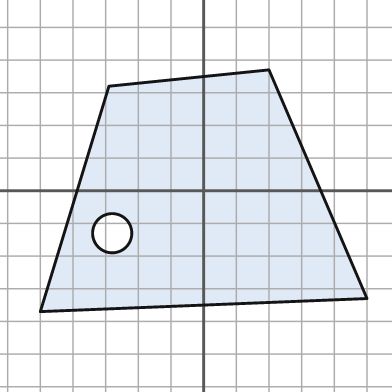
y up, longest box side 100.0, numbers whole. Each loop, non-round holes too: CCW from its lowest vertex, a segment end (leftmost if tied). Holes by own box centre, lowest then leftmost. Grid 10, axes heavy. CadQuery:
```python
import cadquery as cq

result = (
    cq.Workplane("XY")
    .moveTo(-50.0, -37.0)
    .lineTo(50.0, -33.0)
    .lineTo(20.0, 37.0)
    .lineTo(-29.0, 32.0)
    .close()
    .moveTo(-28.0, -13.0)
    .circle(6.0)
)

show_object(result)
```